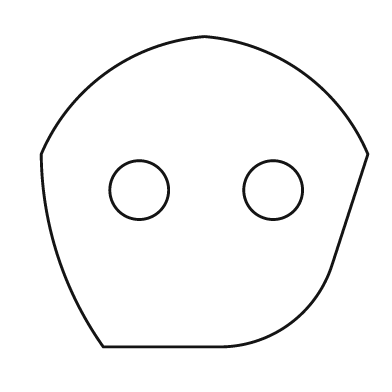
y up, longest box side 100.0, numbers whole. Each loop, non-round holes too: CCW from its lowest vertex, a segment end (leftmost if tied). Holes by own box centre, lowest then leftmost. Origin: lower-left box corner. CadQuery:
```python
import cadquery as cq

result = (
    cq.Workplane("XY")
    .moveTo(19.0, 0.0)
    .lineTo(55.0, 0.0)
    .threePointArc((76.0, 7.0), (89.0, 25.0))
    .lineTo(100.0, 59.0)
    .threePointArc((80.0, 84.0), (50.0, 95.0))
    .threePointArc((20.0, 84.0), (0.0, 59.0))
    .threePointArc((5.0, 28.0), (19.0, 0.0))
    .close()
    .moveTo(30.0, 48.0)
    .circle(9.0)
    .moveTo(71.0, 48.0)
    .circle(9.0)
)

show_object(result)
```